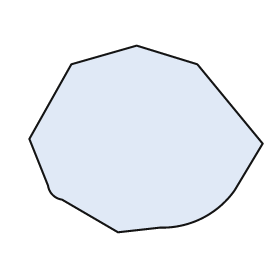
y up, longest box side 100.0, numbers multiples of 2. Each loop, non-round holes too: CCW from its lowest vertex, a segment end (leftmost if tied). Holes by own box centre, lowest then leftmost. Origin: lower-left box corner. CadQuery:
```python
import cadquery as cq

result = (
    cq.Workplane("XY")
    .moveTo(38.0, 0.0)
    .lineTo(56.0, 2.0)
    .threePointArc((74.0, 6.0), (88.0, 18.0))
    .lineTo(100.0, 38.0)
    .lineTo(72.0, 72.0)
    .lineTo(46.0, 80.0)
    .lineTo(18.0, 72.0)
    .lineTo(0.0, 40.0)
    .lineTo(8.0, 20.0)
    .threePointArc((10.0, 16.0), (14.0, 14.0))
    .close()
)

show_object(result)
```